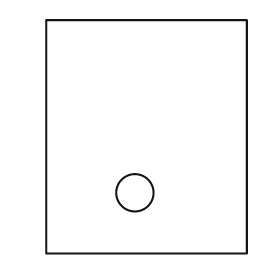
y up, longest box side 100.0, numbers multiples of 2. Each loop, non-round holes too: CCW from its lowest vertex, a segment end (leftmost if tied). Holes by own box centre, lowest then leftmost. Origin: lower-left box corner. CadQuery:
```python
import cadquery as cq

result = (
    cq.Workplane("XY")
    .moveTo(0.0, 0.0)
    .lineTo(86.0, 0.0)
    .lineTo(86.0, 100.0)
    .lineTo(0.0, 100.0)
    .close()
    .moveTo(38.0, 26.0)
    .circle(8.0)
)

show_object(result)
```